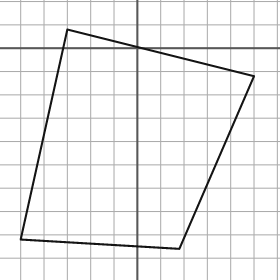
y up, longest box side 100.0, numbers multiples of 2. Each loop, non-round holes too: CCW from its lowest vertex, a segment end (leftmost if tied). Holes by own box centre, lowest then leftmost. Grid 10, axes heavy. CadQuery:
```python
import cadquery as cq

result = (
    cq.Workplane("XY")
    .moveTo(18.0, -86.0)
    .lineTo(50.0, -12.0)
    .lineTo(-30.0, 8.0)
    .lineTo(-50.0, -82.0)
    .close()
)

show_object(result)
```